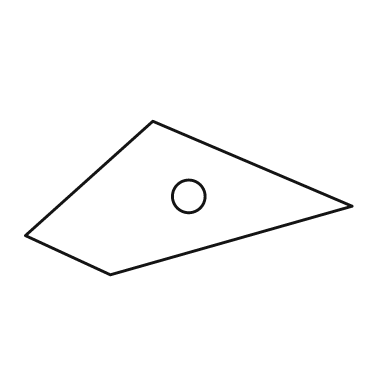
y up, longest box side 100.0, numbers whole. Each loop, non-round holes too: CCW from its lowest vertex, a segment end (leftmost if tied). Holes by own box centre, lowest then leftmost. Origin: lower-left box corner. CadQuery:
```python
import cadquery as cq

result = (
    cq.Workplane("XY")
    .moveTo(26.0, 0.0)
    .lineTo(100.0, 21.0)
    .lineTo(39.0, 47.0)
    .lineTo(0.0, 12.0)
    .close()
    .moveTo(50.0, 24.0)
    .circle(5.0)
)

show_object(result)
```